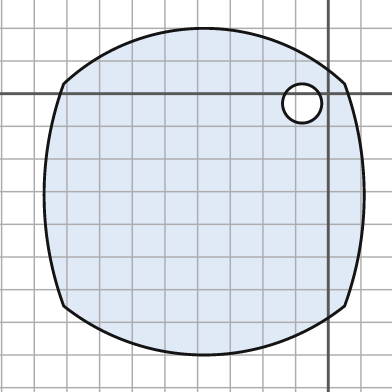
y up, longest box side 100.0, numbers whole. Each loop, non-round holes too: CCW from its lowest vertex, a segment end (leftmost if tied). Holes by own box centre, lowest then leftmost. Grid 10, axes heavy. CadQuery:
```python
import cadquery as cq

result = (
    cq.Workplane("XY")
    .moveTo(-81.0, -65.0)
    .threePointArc((-38.0, -80.0), (5.0, -65.0))
    .threePointArc((11.0, -31.0), (5.0, 3.0))
    .threePointArc((-38.0, 20.0), (-81.0, 3.0))
    .threePointArc((-87.0, -31.0), (-81.0, -65.0))
    .close()
    .moveTo(-8.0, -3.0)
    .circle(6.0)
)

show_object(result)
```